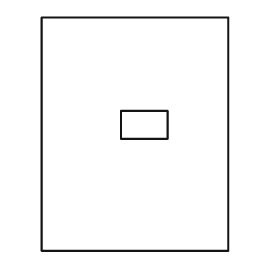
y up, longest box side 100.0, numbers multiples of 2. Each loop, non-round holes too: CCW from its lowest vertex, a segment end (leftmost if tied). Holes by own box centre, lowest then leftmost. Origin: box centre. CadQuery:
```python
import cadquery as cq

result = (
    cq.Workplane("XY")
    .moveTo(-40.0, -50.0)
    .lineTo(40.0, -50.0)
    .lineTo(40.0, 50.0)
    .lineTo(-40.0, 50.0)
    .close()
    .moveTo(-6.0, -2.0)
    .lineTo(14.0, -2.0)
    .lineTo(14.0, 10.0)
    .lineTo(-6.0, 10.0)
    .close()
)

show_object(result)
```